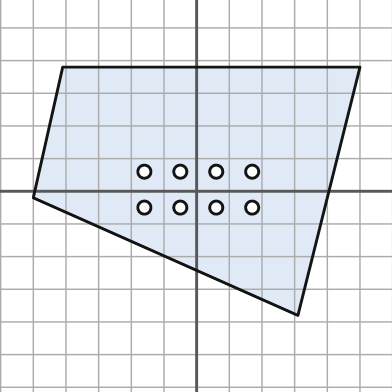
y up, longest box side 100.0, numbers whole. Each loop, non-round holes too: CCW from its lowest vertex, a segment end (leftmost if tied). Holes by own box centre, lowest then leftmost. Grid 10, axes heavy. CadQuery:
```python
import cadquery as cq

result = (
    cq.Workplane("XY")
    .moveTo(31.0, -38.0)
    .lineTo(50.0, 38.0)
    .lineTo(-41.0, 38.0)
    .lineTo(-50.0, -2.0)
    .close()
    .moveTo(-16.0, -5.0)
    .circle(2.0)
    .moveTo(-5.0, -5.0)
    .circle(2.0)
    .moveTo(6.0, -5.0)
    .circle(2.0)
    .moveTo(17.0, -5.0)
    .circle(2.0)
    .moveTo(-16.0, 6.0)
    .circle(2.0)
    .moveTo(-5.0, 6.0)
    .circle(2.0)
    .moveTo(6.0, 6.0)
    .circle(2.0)
    .moveTo(17.0, 6.0)
    .circle(2.0)
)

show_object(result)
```